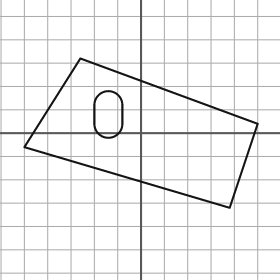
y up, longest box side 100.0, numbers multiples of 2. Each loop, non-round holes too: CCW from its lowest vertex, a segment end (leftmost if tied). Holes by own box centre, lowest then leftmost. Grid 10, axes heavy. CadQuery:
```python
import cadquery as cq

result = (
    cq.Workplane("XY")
    .moveTo(38.0, -32.0)
    .lineTo(50.0, 4.0)
    .lineTo(-26.0, 32.0)
    .lineTo(-50.0, -6.0)
    .close()
    .moveTo(-20.0, 4.0)
    .threePointArc((-14.0, -2.0), (-8.0, 4.0))
    .lineTo(-8.0, 12.0)
    .threePointArc((-14.0, 18.0), (-20.0, 12.0))
    .close()
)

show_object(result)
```